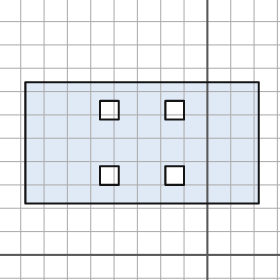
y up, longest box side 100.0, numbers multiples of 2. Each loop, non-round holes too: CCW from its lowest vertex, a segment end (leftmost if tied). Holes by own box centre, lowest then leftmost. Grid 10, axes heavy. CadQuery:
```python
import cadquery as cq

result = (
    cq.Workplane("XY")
    .moveTo(-78.0, 22.0)
    .lineTo(22.0, 22.0)
    .lineTo(22.0, 74.0)
    .lineTo(-78.0, 74.0)
    .close()
    .moveTo(-46.0, 30.0)
    .lineTo(-38.0, 30.0)
    .lineTo(-38.0, 38.0)
    .lineTo(-46.0, 38.0)
    .close()
    .moveTo(-18.0, 30.0)
    .lineTo(-10.0, 30.0)
    .lineTo(-10.0, 38.0)
    .lineTo(-18.0, 38.0)
    .close()
    .moveTo(-46.0, 58.0)
    .lineTo(-38.0, 58.0)
    .lineTo(-38.0, 66.0)
    .lineTo(-46.0, 66.0)
    .close()
    .moveTo(-18.0, 58.0)
    .lineTo(-10.0, 58.0)
    .lineTo(-10.0, 66.0)
    .lineTo(-18.0, 66.0)
    .close()
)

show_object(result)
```